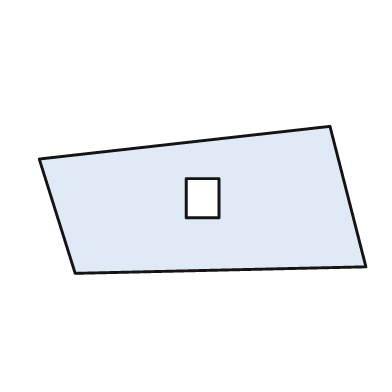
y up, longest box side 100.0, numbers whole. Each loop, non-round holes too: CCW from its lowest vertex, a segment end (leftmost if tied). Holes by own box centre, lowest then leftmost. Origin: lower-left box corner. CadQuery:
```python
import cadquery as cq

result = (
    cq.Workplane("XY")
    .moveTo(11.0, 0.0)
    .lineTo(100.0, 2.0)
    .lineTo(89.0, 45.0)
    .lineTo(0.0, 35.0)
    .close()
    .moveTo(45.0, 17.0)
    .lineTo(55.0, 17.0)
    .lineTo(55.0, 29.0)
    .lineTo(45.0, 29.0)
    .close()
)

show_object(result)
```